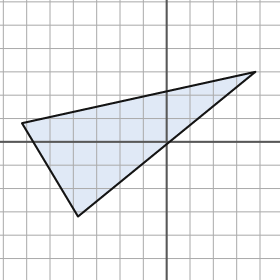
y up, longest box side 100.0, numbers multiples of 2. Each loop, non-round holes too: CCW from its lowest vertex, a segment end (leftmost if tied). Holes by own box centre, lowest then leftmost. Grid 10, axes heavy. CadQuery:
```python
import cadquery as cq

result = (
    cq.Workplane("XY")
    .moveTo(-38.0, -32.0)
    .lineTo(38.0, 30.0)
    .lineTo(-62.0, 8.0)
    .close()
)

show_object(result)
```